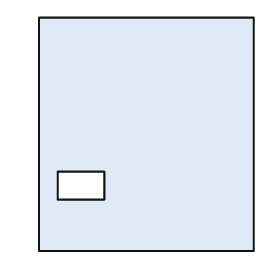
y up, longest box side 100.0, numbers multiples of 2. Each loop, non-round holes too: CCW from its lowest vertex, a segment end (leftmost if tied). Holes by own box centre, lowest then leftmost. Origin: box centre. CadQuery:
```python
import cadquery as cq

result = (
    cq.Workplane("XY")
    .moveTo(-46.0, -50.0)
    .lineTo(46.0, -50.0)
    .lineTo(46.0, 50.0)
    .lineTo(-46.0, 50.0)
    .close()
    .moveTo(-38.0, -28.0)
    .lineTo(-18.0, -28.0)
    .lineTo(-18.0, -16.0)
    .lineTo(-38.0, -16.0)
    .close()
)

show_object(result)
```